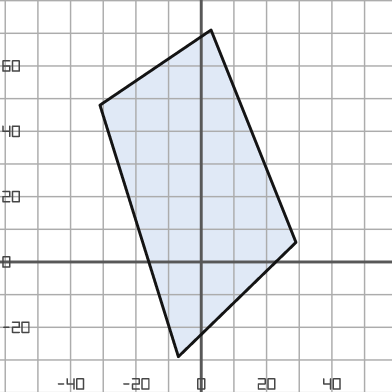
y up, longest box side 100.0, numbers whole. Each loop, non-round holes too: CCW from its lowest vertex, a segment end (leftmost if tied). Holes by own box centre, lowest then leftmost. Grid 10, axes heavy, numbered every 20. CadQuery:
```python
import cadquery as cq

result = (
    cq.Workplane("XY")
    .moveTo(-7.0, -29.0)
    .lineTo(29.0, 6.0)
    .lineTo(3.0, 71.0)
    .lineTo(-31.0, 48.0)
    .close()
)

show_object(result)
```